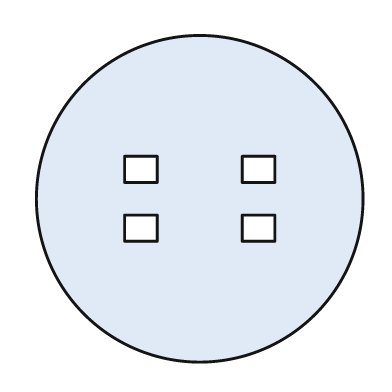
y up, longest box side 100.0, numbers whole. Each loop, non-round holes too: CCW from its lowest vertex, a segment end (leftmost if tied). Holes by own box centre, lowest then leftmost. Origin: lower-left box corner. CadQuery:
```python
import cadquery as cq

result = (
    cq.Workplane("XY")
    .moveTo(50.0, 50.0)
    .circle(50.0)
    .moveTo(27.0, 37.0)
    .lineTo(37.0, 37.0)
    .lineTo(37.0, 45.0)
    .lineTo(27.0, 45.0)
    .close()
    .moveTo(63.0, 37.0)
    .lineTo(73.0, 37.0)
    .lineTo(73.0, 45.0)
    .lineTo(63.0, 45.0)
    .close()
    .moveTo(27.0, 55.0)
    .lineTo(37.0, 55.0)
    .lineTo(37.0, 63.0)
    .lineTo(27.0, 63.0)
    .close()
    .moveTo(63.0, 55.0)
    .lineTo(73.0, 55.0)
    .lineTo(73.0, 63.0)
    .lineTo(63.0, 63.0)
    .close()
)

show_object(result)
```